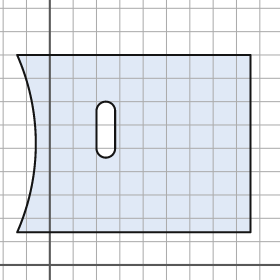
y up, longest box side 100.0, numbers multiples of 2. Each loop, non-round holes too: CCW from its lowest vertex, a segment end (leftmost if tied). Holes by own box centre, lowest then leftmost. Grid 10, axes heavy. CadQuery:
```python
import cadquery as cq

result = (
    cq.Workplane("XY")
    .moveTo(-14.0, 14.0)
    .lineTo(86.0, 14.0)
    .lineTo(86.0, 90.0)
    .lineTo(-14.0, 90.0)
    .threePointArc((-6.0, 52.0), (-14.0, 14.0))
    .close()
    .moveTo(20.0, 50.0)
    .threePointArc((24.0, 46.0), (28.0, 50.0))
    .lineTo(28.0, 66.0)
    .threePointArc((24.0, 70.0), (20.0, 66.0))
    .close()
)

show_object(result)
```